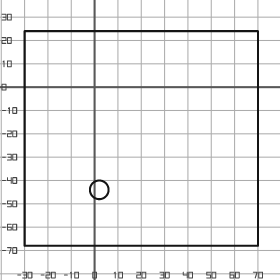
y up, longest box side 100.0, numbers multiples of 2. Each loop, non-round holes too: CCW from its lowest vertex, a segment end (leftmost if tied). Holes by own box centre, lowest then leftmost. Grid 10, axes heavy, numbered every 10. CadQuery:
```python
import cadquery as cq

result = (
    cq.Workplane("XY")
    .moveTo(-30.0, -68.0)
    .lineTo(70.0, -68.0)
    .lineTo(70.0, 24.0)
    .lineTo(-30.0, 24.0)
    .close()
    .moveTo(2.0, -44.0)
    .circle(4.0)
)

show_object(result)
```